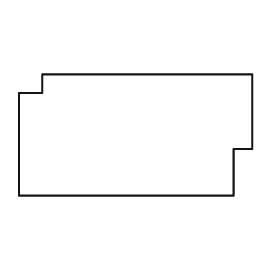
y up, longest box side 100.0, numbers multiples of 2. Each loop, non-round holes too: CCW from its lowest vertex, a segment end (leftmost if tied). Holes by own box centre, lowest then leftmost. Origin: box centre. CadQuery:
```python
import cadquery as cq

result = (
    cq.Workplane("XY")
    .moveTo(-50.0, -26.0)
    .lineTo(42.0, -26.0)
    .lineTo(42.0, -6.0)
    .lineTo(50.0, -6.0)
    .lineTo(50.0, 26.0)
    .lineTo(-40.0, 26.0)
    .lineTo(-40.0, 18.0)
    .lineTo(-50.0, 18.0)
    .close()
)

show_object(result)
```